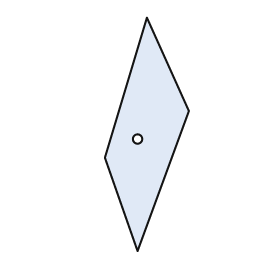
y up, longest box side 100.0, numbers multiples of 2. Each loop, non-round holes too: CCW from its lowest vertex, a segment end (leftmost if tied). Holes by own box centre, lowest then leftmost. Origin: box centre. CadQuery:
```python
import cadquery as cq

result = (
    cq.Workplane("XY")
    .moveTo(-4.0, -50.0)
    .lineTo(18.0, 10.0)
    .lineTo(0.0, 50.0)
    .lineTo(-18.0, -10.0)
    .close()
    .moveTo(-4.0, -2.0)
    .circle(2.0)
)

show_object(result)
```